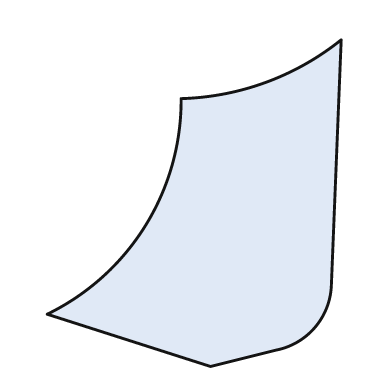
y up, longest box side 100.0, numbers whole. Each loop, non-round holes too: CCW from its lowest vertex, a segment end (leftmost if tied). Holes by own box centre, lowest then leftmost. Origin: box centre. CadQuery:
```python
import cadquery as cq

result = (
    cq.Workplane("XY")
    .moveTo(5.0, -50.0)
    .lineTo(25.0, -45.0)
    .threePointArc((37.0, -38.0), (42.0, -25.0))
    .lineTo(45.0, 50.0)
    .threePointArc((22.0, 37.0), (-4.0, 32.0))
    .threePointArc((-15.0, -7.0), (-45.0, -34.0))
    .close()
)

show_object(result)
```